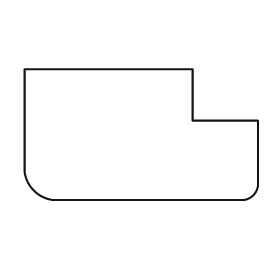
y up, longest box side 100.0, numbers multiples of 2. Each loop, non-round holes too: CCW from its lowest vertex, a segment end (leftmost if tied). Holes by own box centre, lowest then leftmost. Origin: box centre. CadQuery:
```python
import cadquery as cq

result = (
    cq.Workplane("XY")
    .moveTo(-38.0, -28.0)
    .lineTo(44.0, -28.0)
    .threePointArc((48.0, -26.0), (50.0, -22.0))
    .lineTo(50.0, 6.0)
    .lineTo(22.0, 6.0)
    .lineTo(22.0, 28.0)
    .lineTo(-50.0, 28.0)
    .lineTo(-50.0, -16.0)
    .threePointArc((-46.0, -24.0), (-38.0, -28.0))
    .close()
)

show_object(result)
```